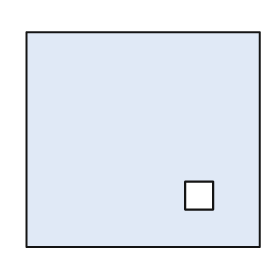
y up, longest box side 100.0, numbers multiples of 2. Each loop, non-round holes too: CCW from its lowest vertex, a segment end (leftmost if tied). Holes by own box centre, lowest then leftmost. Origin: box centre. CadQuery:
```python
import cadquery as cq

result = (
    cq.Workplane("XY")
    .moveTo(-50.0, -46.0)
    .lineTo(50.0, -46.0)
    .lineTo(50.0, 46.0)
    .lineTo(-50.0, 46.0)
    .close()
    .moveTo(18.0, -30.0)
    .lineTo(30.0, -30.0)
    .lineTo(30.0, -18.0)
    .lineTo(18.0, -18.0)
    .close()
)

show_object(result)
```